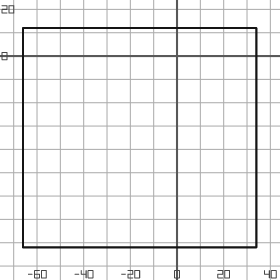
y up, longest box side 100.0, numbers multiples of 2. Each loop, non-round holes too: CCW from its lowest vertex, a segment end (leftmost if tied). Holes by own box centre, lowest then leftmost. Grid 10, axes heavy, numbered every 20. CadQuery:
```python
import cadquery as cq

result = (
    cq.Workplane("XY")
    .moveTo(-66.0, -82.0)
    .lineTo(34.0, -82.0)
    .lineTo(34.0, 12.0)
    .lineTo(-66.0, 12.0)
    .close()
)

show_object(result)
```